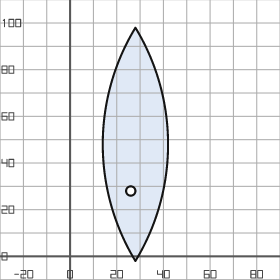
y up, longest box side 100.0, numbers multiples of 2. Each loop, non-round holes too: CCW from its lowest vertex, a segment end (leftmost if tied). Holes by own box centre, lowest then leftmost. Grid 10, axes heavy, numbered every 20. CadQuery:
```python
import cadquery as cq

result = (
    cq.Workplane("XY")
    .moveTo(28.0, -2.0)
    .threePointArc((42.0, 48.0), (28.0, 98.0))
    .threePointArc((14.0, 48.0), (28.0, -2.0))
    .close()
    .moveTo(26.0, 28.0)
    .circle(2.0)
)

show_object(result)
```